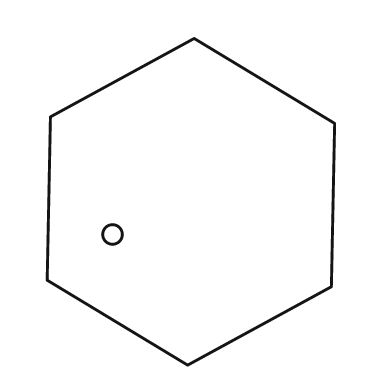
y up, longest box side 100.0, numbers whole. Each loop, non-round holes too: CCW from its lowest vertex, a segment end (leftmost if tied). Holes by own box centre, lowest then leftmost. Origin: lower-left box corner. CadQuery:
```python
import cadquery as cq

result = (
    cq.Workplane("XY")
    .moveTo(43.0, 0.0)
    .lineTo(87.0, 24.0)
    .lineTo(88.0, 74.0)
    .lineTo(45.0, 100.0)
    .lineTo(1.0, 76.0)
    .lineTo(0.0, 26.0)
    .close()
    .moveTo(20.0, 40.0)
    .circle(3.0)
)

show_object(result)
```